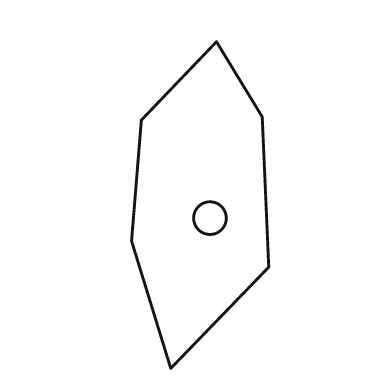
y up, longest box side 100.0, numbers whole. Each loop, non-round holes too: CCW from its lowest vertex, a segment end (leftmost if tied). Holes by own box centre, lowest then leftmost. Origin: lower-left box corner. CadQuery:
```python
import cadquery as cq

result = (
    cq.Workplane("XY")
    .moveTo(12.0, 0.0)
    .lineTo(42.0, 31.0)
    .lineTo(40.0, 77.0)
    .lineTo(26.0, 100.0)
    .lineTo(3.0, 76.0)
    .lineTo(0.0, 39.0)
    .close()
    .moveTo(24.0, 46.0)
    .circle(5.0)
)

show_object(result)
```